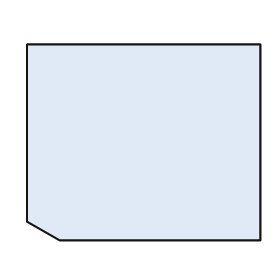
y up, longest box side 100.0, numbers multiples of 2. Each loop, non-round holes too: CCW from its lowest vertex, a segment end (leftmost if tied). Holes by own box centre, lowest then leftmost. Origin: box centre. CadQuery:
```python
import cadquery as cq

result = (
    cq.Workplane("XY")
    .moveTo(-36.0, -42.0)
    .lineTo(50.0, -42.0)
    .lineTo(50.0, 42.0)
    .lineTo(-50.0, 42.0)
    .lineTo(-50.0, -34.0)
    .close()
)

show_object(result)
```